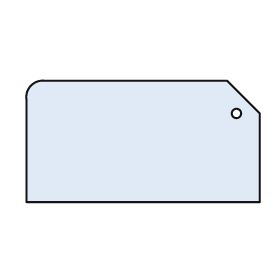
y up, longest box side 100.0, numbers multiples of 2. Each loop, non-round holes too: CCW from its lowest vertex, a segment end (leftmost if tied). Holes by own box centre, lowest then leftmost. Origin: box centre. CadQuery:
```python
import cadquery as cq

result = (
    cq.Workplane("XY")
    .moveTo(-50.0, -26.0)
    .lineTo(50.0, -26.0)
    .lineTo(50.0, 12.0)
    .lineTo(36.0, 26.0)
    .lineTo(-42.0, 26.0)
    .threePointArc((-48.0, 24.0), (-50.0, 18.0))
    .close()
    .moveTo(40.0, 12.0)
    .circle(2.0)
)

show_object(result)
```